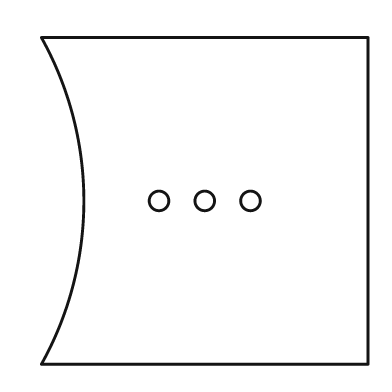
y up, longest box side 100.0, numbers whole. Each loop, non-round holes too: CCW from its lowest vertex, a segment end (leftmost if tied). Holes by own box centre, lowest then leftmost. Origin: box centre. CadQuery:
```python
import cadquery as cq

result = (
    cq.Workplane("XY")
    .moveTo(-50.0, -50.0)
    .lineTo(50.0, -50.0)
    .lineTo(50.0, 50.0)
    .lineTo(-50.0, 50.0)
    .threePointArc((-37.0, 0.0), (-50.0, -50.0))
    .close()
    .moveTo(-14.0, 0.0)
    .circle(3.0)
    .moveTo(0.0, 0.0)
    .circle(3.0)
    .moveTo(14.0, 0.0)
    .circle(3.0)
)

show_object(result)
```